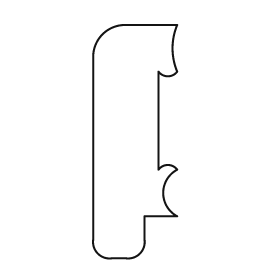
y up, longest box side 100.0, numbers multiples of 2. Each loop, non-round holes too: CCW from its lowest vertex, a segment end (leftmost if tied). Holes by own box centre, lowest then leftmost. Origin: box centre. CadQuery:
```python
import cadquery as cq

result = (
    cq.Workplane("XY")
    .moveTo(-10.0, -50.0)
    .lineTo(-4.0, -50.0)
    .threePointArc((2.0, -48.0), (4.0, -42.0))
    .lineTo(4.0, -32.0)
    .lineTo(18.0, -32.0)
    .threePointArc((12.0, -22.0), (18.0, -12.0))
    .threePointArc((14.0, -10.0), (10.0, -12.0))
    .lineTo(10.0, 30.0)
    .threePointArc((14.0, 28.0), (18.0, 30.0))
    .threePointArc((16.0, 40.0), (18.0, 50.0))
    .lineTo(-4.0, 50.0)
    .threePointArc((-14.0, 46.0), (-18.0, 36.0))
    .lineTo(-18.0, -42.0)
    .threePointArc((-16.0, -48.0), (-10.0, -50.0))
    .close()
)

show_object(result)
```